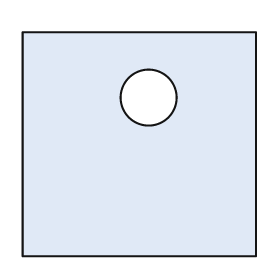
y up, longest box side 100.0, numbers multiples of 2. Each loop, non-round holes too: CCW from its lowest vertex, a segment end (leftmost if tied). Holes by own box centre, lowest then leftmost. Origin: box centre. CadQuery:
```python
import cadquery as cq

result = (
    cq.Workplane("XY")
    .moveTo(-50.0, -48.0)
    .lineTo(50.0, -48.0)
    .lineTo(50.0, 48.0)
    .lineTo(-50.0, 48.0)
    .close()
    .moveTo(4.0, 20.0)
    .circle(12.0)
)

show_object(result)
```